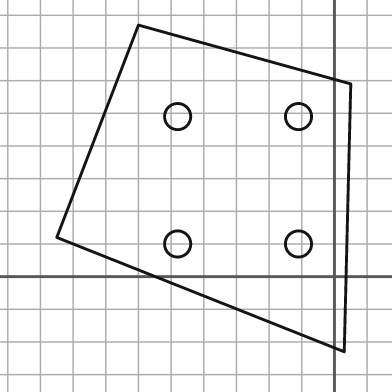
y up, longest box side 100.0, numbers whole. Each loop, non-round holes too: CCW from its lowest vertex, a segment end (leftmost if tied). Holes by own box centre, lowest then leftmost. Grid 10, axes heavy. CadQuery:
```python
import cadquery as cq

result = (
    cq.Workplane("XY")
    .moveTo(3.0, -23.0)
    .lineTo(5.0, 59.0)
    .lineTo(-60.0, 77.0)
    .lineTo(-85.0, 12.0)
    .close()
    .moveTo(-48.0, 10.0)
    .circle(4.0)
    .moveTo(-11.0, 10.0)
    .circle(4.0)
    .moveTo(-48.0, 49.0)
    .circle(4.0)
    .moveTo(-11.0, 49.0)
    .circle(4.0)
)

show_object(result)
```